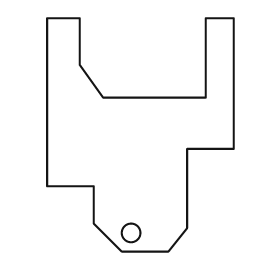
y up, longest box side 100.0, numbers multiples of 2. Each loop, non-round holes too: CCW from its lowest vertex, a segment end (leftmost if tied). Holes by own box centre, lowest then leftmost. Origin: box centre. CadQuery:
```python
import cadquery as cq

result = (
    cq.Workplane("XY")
    .moveTo(-8.0, -50.0)
    .lineTo(12.0, -50.0)
    .lineTo(20.0, -40.0)
    .lineTo(20.0, -6.0)
    .lineTo(40.0, -6.0)
    .lineTo(40.0, 50.0)
    .lineTo(28.0, 50.0)
    .lineTo(28.0, 16.0)
    .lineTo(-16.0, 16.0)
    .lineTo(-26.0, 30.0)
    .lineTo(-26.0, 50.0)
    .lineTo(-40.0, 50.0)
    .lineTo(-40.0, -22.0)
    .lineTo(-20.0, -22.0)
    .lineTo(-20.0, -38.0)
    .close()
    .moveTo(-4.0, -42.0)
    .circle(4.0)
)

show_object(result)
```